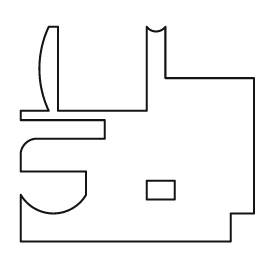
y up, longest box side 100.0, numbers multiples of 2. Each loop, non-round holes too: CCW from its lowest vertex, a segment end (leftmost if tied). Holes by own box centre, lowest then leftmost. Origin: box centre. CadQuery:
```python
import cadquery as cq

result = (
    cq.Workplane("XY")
    .moveTo(-50.0, -46.0)
    .lineTo(40.0, -46.0)
    .lineTo(40.0, -34.0)
    .lineTo(50.0, -34.0)
    .lineTo(50.0, 24.0)
    .lineTo(12.0, 24.0)
    .lineTo(12.0, 46.0)
    .threePointArc((8.0, 44.0), (4.0, 46.0))
    .lineTo(4.0, 10.0)
    .lineTo(-34.0, 10.0)
    .lineTo(-34.0, 46.0)
    .lineTo(-38.0, 46.0)
    .threePointArc((-42.0, 28.0), (-38.0, 10.0))
    .lineTo(-50.0, 10.0)
    .lineTo(-50.0, 6.0)
    .lineTo(-14.0, 6.0)
    .lineTo(-14.0, -2.0)
    .lineTo(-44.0, -2.0)
    .threePointArc((-48.0, -4.0), (-50.0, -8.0))
    .lineTo(-50.0, -16.0)
    .lineTo(-22.0, -16.0)
    .lineTo(-22.0, -26.0)
    .threePointArc((-36.0, -34.0), (-50.0, -26.0))
    .close()
    .moveTo(4.0, -28.0)
    .lineTo(16.0, -28.0)
    .lineTo(16.0, -20.0)
    .lineTo(4.0, -20.0)
    .close()
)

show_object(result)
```